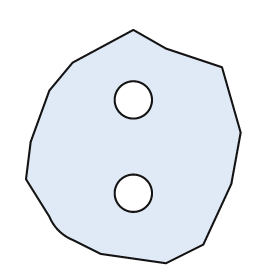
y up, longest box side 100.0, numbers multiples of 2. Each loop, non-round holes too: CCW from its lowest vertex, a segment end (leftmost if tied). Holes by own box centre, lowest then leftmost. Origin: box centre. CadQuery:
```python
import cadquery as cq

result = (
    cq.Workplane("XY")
    .moveTo(14.0, -50.0)
    .lineTo(30.0, -42.0)
    .lineTo(42.0, -16.0)
    .lineTo(46.0, 6.0)
    .lineTo(38.0, 34.0)
    .lineTo(14.0, 42.0)
    .lineTo(0.0, 50.0)
    .lineTo(-26.0, 36.0)
    .lineTo(-36.0, 24.0)
    .lineTo(-44.0, 2.0)
    .lineTo(-46.0, -14.0)
    .lineTo(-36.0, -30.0)
    .threePointArc((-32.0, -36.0), (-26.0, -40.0))
    .lineTo(-14.0, -46.0)
    .close()
    .moveTo(0.0, -20.0)
    .circle(8.0)
    .moveTo(0.0, 20.0)
    .circle(8.0)
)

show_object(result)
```